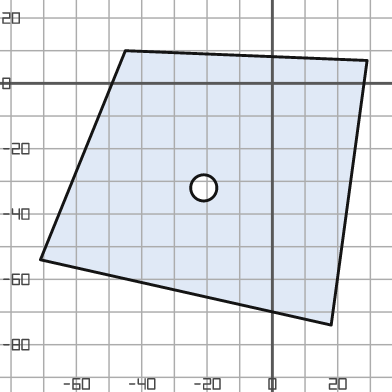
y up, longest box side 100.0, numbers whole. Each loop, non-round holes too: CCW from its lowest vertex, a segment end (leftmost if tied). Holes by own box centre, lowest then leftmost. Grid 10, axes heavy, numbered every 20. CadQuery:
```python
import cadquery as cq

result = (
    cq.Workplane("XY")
    .moveTo(18.0, -74.0)
    .lineTo(29.0, 7.0)
    .lineTo(-45.0, 10.0)
    .lineTo(-71.0, -54.0)
    .close()
    .moveTo(-21.0, -32.0)
    .circle(4.0)
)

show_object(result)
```